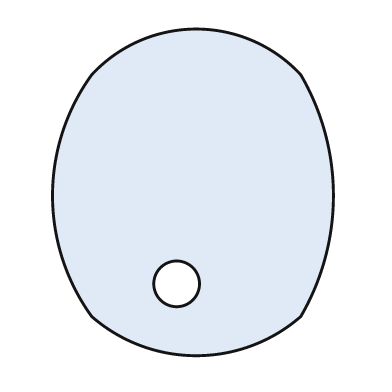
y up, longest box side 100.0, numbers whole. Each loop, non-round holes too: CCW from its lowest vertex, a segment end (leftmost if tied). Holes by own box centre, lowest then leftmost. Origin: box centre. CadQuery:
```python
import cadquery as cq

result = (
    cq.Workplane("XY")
    .moveTo(-31.0, -38.0)
    .threePointArc((1.0, -50.0), (33.0, -38.0))
    .threePointArc((43.0, -1.0), (33.0, 36.0))
    .threePointArc((1.0, 50.0), (-31.0, 36.0))
    .threePointArc((-43.0, -1.0), (-31.0, -38.0))
    .close()
    .moveTo(-5.0, -28.0)
    .circle(7.0)
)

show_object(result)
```